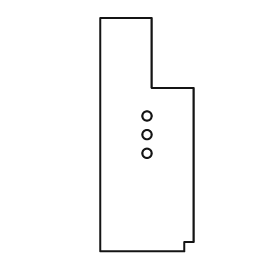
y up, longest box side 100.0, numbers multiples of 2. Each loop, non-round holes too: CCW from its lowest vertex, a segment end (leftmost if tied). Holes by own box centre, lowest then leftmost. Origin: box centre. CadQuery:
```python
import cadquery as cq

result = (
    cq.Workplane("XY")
    .moveTo(-20.0, -50.0)
    .lineTo(16.0, -50.0)
    .lineTo(16.0, -46.0)
    .lineTo(20.0, -46.0)
    .lineTo(20.0, 20.0)
    .lineTo(2.0, 20.0)
    .lineTo(2.0, 50.0)
    .lineTo(-20.0, 50.0)
    .close()
    .moveTo(0.0, -8.0)
    .circle(2.0)
    .moveTo(0.0, 0.0)
    .circle(2.0)
    .moveTo(0.0, 8.0)
    .circle(2.0)
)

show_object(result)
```